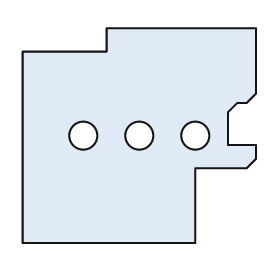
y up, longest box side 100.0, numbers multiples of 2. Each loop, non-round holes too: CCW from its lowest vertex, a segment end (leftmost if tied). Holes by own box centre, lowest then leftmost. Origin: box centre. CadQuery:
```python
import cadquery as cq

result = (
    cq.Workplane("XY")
    .moveTo(-50.0, -46.0)
    .lineTo(24.0, -46.0)
    .lineTo(24.0, -14.0)
    .lineTo(46.0, -14.0)
    .lineTo(50.0, -10.0)
    .lineTo(50.0, -4.0)
    .lineTo(38.0, -4.0)
    .lineTo(38.0, 10.0)
    .lineTo(42.0, 14.0)
    .lineTo(46.0, 14.0)
    .lineTo(50.0, 18.0)
    .lineTo(50.0, 46.0)
    .lineTo(-14.0, 46.0)
    .lineTo(-14.0, 36.0)
    .lineTo(-50.0, 36.0)
    .close()
    .moveTo(-24.0, 0.0)
    .circle(6.0)
    .moveTo(0.0, 0.0)
    .circle(6.0)
    .moveTo(24.0, 0.0)
    .circle(6.0)
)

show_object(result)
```